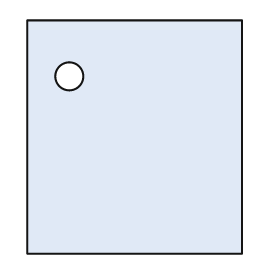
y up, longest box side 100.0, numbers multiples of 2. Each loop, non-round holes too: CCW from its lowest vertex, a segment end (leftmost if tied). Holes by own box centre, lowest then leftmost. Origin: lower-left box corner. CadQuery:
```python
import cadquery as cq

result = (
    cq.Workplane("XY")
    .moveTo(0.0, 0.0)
    .lineTo(92.0, 0.0)
    .lineTo(92.0, 100.0)
    .lineTo(0.0, 100.0)
    .close()
    .moveTo(18.0, 76.0)
    .circle(6.0)
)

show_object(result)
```